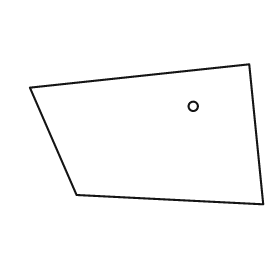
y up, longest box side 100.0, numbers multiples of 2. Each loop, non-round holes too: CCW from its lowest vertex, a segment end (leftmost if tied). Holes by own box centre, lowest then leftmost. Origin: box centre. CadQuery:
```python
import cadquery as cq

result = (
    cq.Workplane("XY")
    .moveTo(50.0, -30.0)
    .lineTo(44.0, 30.0)
    .lineTo(-50.0, 20.0)
    .lineTo(-30.0, -26.0)
    .close()
    .moveTo(20.0, 12.0)
    .circle(2.0)
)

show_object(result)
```